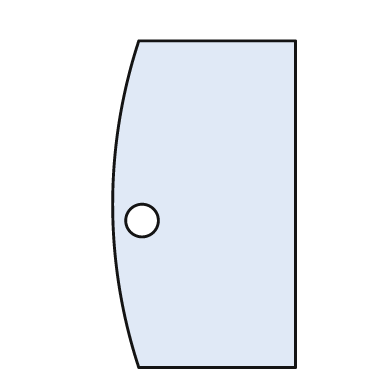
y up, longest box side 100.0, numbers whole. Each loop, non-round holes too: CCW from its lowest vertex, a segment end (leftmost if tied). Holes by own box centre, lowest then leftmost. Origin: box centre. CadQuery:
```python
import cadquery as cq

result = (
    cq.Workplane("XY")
    .moveTo(-20.0, -50.0)
    .lineTo(28.0, -50.0)
    .lineTo(28.0, 50.0)
    .lineTo(-20.0, 50.0)
    .threePointArc((-28.0, 0.0), (-20.0, -50.0))
    .close()
    .moveTo(-19.0, -5.0)
    .circle(5.0)
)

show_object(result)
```